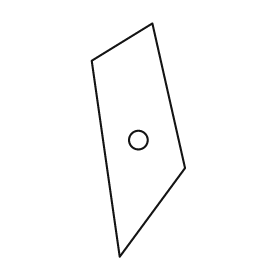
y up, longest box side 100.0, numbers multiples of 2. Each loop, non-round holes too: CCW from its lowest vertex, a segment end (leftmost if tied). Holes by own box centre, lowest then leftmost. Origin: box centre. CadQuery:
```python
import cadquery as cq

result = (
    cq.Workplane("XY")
    .moveTo(-8.0, -50.0)
    .lineTo(20.0, -12.0)
    .lineTo(6.0, 50.0)
    .lineTo(-20.0, 34.0)
    .close()
    .moveTo(0.0, 0.0)
    .circle(4.0)
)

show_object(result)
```